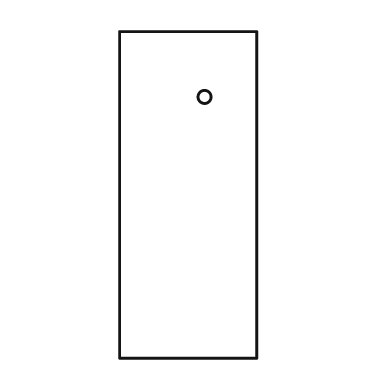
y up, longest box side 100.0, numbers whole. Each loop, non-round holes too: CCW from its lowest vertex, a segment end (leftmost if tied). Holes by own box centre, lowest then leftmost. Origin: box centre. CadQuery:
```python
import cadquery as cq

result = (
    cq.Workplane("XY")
    .moveTo(-21.0, -50.0)
    .lineTo(21.0, -50.0)
    .lineTo(21.0, 50.0)
    .lineTo(-21.0, 50.0)
    .close()
    .moveTo(5.0, 30.0)
    .circle(2.0)
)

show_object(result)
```